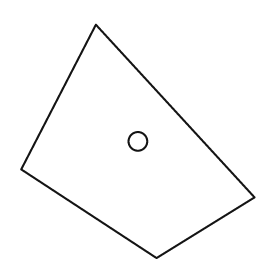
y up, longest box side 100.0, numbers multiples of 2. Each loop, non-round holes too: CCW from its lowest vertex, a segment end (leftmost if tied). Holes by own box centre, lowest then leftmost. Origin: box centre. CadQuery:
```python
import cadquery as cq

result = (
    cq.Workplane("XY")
    .moveTo(8.0, -50.0)
    .lineTo(50.0, -24.0)
    .lineTo(-18.0, 50.0)
    .lineTo(-50.0, -12.0)
    .close()
    .moveTo(0.0, 0.0)
    .circle(4.0)
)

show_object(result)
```